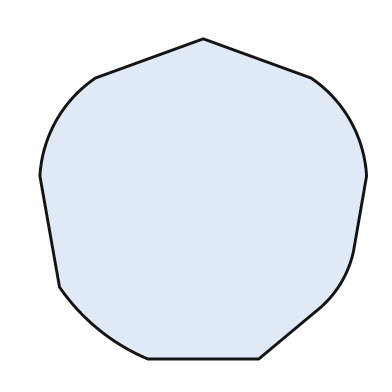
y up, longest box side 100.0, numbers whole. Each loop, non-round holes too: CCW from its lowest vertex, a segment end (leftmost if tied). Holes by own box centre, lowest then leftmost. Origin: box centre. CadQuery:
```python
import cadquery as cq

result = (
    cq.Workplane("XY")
    .moveTo(-17.0, -49.0)
    .lineTo(17.0, -49.0)
    .lineTo(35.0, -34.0)
    .threePointArc((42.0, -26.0), (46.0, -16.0))
    .lineTo(50.0, 7.0)
    .threePointArc((45.0, 24.0), (33.0, 37.0))
    .lineTo(0.0, 49.0)
    .lineTo(-33.0, 37.0)
    .threePointArc((-45.0, 24.0), (-50.0, 7.0))
    .lineTo(-44.0, -27.0)
    .threePointArc((-32.0, -40.0), (-17.0, -49.0))
    .close()
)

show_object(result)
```